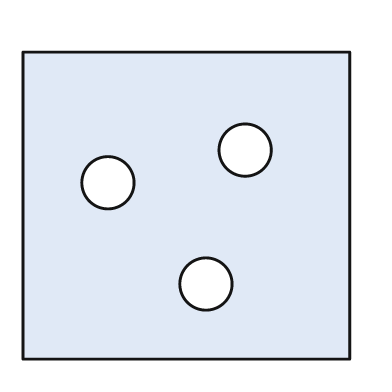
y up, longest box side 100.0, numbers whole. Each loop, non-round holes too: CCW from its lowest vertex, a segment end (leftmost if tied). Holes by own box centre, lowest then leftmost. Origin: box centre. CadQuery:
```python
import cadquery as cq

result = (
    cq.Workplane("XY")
    .moveTo(-50.0, -47.0)
    .lineTo(50.0, -47.0)
    .lineTo(50.0, 47.0)
    .lineTo(-50.0, 47.0)
    .close()
    .moveTo(6.0, -24.0)
    .circle(8.0)
    .moveTo(-24.0, 7.0)
    .circle(8.0)
    .moveTo(18.0, 17.0)
    .circle(8.0)
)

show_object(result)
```